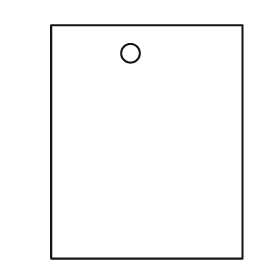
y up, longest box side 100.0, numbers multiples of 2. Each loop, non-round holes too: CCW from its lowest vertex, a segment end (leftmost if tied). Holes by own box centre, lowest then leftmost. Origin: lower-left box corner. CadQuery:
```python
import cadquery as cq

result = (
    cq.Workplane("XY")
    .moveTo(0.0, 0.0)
    .lineTo(82.0, 0.0)
    .lineTo(82.0, 100.0)
    .lineTo(0.0, 100.0)
    .close()
    .moveTo(34.0, 88.0)
    .circle(4.0)
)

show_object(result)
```